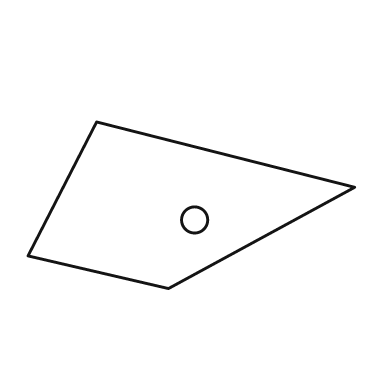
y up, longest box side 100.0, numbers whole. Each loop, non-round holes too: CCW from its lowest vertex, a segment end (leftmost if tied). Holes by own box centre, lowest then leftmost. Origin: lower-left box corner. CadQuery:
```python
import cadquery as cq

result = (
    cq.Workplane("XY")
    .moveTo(43.0, 0.0)
    .lineTo(100.0, 31.0)
    .lineTo(21.0, 51.0)
    .lineTo(0.0, 10.0)
    .close()
    .moveTo(51.0, 21.0)
    .circle(4.0)
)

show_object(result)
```